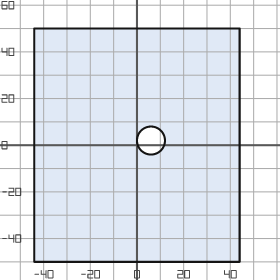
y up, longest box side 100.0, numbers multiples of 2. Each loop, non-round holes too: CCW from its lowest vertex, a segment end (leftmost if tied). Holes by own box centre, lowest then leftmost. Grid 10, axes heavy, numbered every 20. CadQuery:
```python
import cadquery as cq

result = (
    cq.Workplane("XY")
    .moveTo(-44.0, -50.0)
    .lineTo(44.0, -50.0)
    .lineTo(44.0, 50.0)
    .lineTo(-44.0, 50.0)
    .close()
    .moveTo(6.0, 2.0)
    .circle(6.0)
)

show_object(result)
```